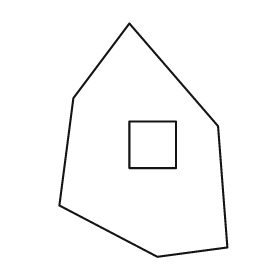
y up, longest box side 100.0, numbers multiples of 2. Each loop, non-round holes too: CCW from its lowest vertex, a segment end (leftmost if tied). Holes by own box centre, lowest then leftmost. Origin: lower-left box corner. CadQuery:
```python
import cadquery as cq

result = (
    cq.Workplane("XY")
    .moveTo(42.0, 0.0)
    .lineTo(72.0, 4.0)
    .lineTo(68.0, 56.0)
    .lineTo(30.0, 100.0)
    .lineTo(6.0, 68.0)
    .lineTo(0.0, 22.0)
    .close()
    .moveTo(30.0, 38.0)
    .lineTo(50.0, 38.0)
    .lineTo(50.0, 58.0)
    .lineTo(30.0, 58.0)
    .close()
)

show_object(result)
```